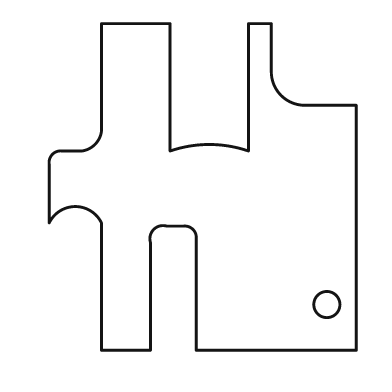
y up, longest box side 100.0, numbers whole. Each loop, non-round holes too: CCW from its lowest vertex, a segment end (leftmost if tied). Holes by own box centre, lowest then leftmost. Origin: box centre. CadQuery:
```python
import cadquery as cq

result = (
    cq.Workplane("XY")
    .moveTo(-31.0, -50.0)
    .lineTo(-16.0, -50.0)
    .lineTo(-16.0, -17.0)
    .threePointArc((-15.0, -13.0), (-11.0, -12.0))
    .lineTo(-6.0, -12.0)
    .threePointArc((-3.0, -13.0), (-2.0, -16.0))
    .lineTo(-2.0, -50.0)
    .lineTo(47.0, -50.0)
    .lineTo(47.0, 25.0)
    .lineTo(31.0, 25.0)
    .threePointArc((24.0, 28.0), (21.0, 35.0))
    .lineTo(21.0, 50.0)
    .lineTo(14.0, 50.0)
    .lineTo(14.0, 11.0)
    .threePointArc((2.0, 13.0), (-10.0, 11.0))
    .lineTo(-10.0, 50.0)
    .lineTo(-31.0, 50.0)
    .lineTo(-31.0, 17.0)
    .threePointArc((-33.0, 13.0), (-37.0, 11.0))
    .lineTo(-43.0, 11.0)
    .threePointArc((-46.0, 10.0), (-47.0, 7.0))
    .lineTo(-47.0, -11.0)
    .threePointArc((-39.0, -6.0), (-31.0, -11.0))
    .close()
    .moveTo(38.0, -36.0)
    .circle(4.0)
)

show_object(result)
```